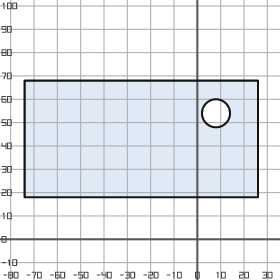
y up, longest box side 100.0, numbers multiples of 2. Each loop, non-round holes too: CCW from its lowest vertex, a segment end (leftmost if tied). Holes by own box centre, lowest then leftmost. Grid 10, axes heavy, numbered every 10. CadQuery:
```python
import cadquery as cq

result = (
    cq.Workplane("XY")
    .moveTo(-74.0, 18.0)
    .lineTo(26.0, 18.0)
    .lineTo(26.0, 68.0)
    .lineTo(-74.0, 68.0)
    .close()
    .moveTo(8.0, 54.0)
    .circle(6.0)
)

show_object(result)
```